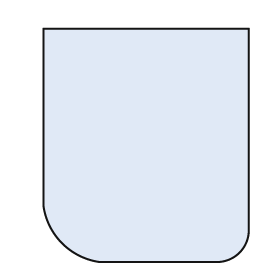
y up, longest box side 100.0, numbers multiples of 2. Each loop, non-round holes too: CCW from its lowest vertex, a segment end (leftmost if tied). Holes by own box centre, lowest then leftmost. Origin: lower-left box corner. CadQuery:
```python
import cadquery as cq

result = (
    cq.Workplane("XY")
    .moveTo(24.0, 0.0)
    .lineTo(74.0, 0.0)
    .threePointArc((84.0, 4.0), (88.0, 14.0))
    .lineTo(88.0, 100.0)
    .lineTo(0.0, 100.0)
    .lineTo(0.0, 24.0)
    .threePointArc((8.0, 8.0), (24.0, 0.0))
    .close()
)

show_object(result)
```